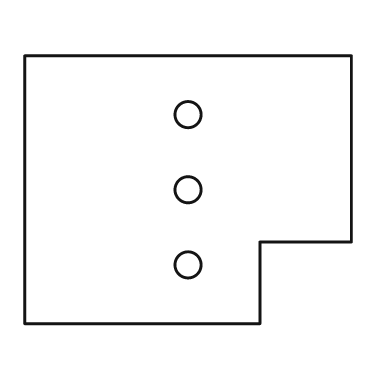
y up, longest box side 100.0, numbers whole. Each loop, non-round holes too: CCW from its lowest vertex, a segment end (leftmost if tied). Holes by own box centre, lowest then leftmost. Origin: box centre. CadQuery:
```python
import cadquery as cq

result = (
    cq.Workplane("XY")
    .moveTo(-50.0, -41.0)
    .lineTo(22.0, -41.0)
    .lineTo(22.0, -16.0)
    .lineTo(50.0, -16.0)
    .lineTo(50.0, 41.0)
    .lineTo(-50.0, 41.0)
    .close()
    .moveTo(0.0, -23.0)
    .circle(4.0)
    .moveTo(0.0, 0.0)
    .circle(4.0)
    .moveTo(0.0, 23.0)
    .circle(4.0)
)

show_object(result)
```